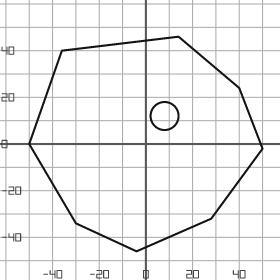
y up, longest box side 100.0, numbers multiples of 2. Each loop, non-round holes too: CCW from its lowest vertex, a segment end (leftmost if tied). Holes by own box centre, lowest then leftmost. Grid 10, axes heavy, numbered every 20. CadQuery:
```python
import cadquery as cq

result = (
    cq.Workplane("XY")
    .moveTo(-4.0, -46.0)
    .lineTo(28.0, -32.0)
    .lineTo(50.0, -2.0)
    .lineTo(40.0, 24.0)
    .lineTo(14.0, 46.0)
    .lineTo(-36.0, 40.0)
    .lineTo(-50.0, 0.0)
    .lineTo(-30.0, -34.0)
    .close()
    .moveTo(8.0, 12.0)
    .circle(6.0)
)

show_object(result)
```